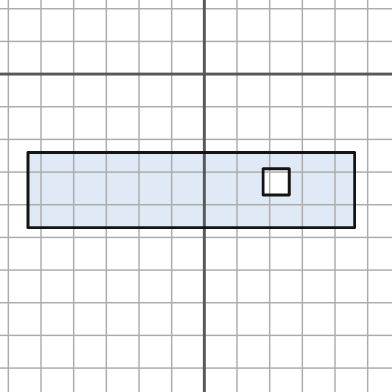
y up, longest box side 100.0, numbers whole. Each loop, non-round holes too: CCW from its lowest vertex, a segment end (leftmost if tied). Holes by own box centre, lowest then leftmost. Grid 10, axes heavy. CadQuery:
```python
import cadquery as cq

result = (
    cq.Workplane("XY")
    .moveTo(-54.0, -47.0)
    .lineTo(46.0, -47.0)
    .lineTo(46.0, -24.0)
    .lineTo(-54.0, -24.0)
    .close()
    .moveTo(18.0, -37.0)
    .lineTo(26.0, -37.0)
    .lineTo(26.0, -29.0)
    .lineTo(18.0, -29.0)
    .close()
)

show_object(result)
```